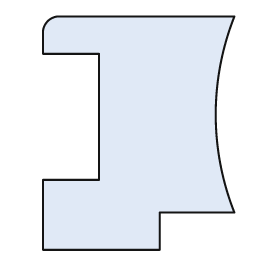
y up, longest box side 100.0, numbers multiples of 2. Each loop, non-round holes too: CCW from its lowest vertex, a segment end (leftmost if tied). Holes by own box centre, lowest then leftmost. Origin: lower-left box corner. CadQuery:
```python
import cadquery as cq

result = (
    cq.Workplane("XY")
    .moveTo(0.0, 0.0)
    .lineTo(50.0, 0.0)
    .lineTo(50.0, 16.0)
    .lineTo(82.0, 16.0)
    .threePointArc((74.0, 58.0), (82.0, 100.0))
    .lineTo(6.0, 100.0)
    .threePointArc((2.0, 98.0), (0.0, 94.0))
    .lineTo(0.0, 84.0)
    .lineTo(24.0, 84.0)
    .lineTo(24.0, 30.0)
    .lineTo(0.0, 30.0)
    .close()
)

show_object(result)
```